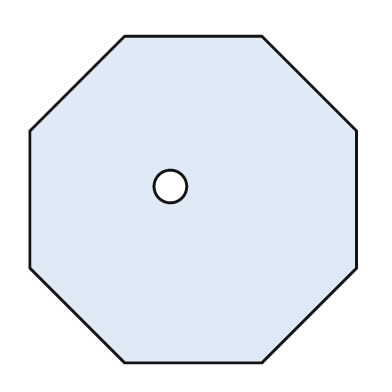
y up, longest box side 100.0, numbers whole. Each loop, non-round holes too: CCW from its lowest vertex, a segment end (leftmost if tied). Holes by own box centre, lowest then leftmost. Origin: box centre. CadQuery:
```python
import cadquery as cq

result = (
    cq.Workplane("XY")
    .moveTo(-21.0, -50.0)
    .lineTo(21.0, -50.0)
    .lineTo(50.0, -21.0)
    .lineTo(50.0, 21.0)
    .lineTo(21.0, 50.0)
    .lineTo(-21.0, 50.0)
    .lineTo(-50.0, 21.0)
    .lineTo(-50.0, -21.0)
    .close()
    .moveTo(-7.0, 4.0)
    .circle(5.0)
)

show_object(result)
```